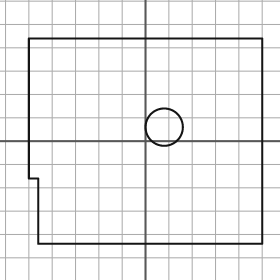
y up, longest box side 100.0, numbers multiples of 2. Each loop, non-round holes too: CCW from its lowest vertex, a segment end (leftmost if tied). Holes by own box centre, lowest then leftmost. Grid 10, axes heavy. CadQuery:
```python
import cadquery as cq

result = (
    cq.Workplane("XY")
    .moveTo(-46.0, -44.0)
    .lineTo(50.0, -44.0)
    .lineTo(50.0, 44.0)
    .lineTo(-50.0, 44.0)
    .lineTo(-50.0, -16.0)
    .lineTo(-46.0, -16.0)
    .close()
    .moveTo(8.0, 6.0)
    .circle(8.0)
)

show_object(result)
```